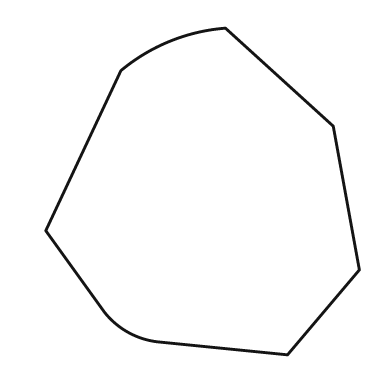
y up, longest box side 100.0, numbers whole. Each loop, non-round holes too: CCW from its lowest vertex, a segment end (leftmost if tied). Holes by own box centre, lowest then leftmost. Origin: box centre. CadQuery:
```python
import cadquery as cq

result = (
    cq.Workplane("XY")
    .moveTo(26.0, -50.0)
    .lineTo(48.0, -24.0)
    .lineTo(40.0, 20.0)
    .lineTo(7.0, 50.0)
    .threePointArc((-10.0, 46.0), (-25.0, 37.0))
    .lineTo(-48.0, -12.0)
    .lineTo(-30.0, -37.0)
    .threePointArc((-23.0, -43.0), (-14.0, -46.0))
    .close()
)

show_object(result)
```